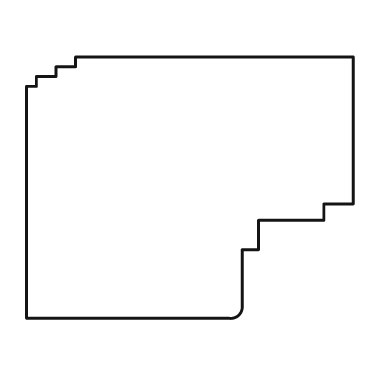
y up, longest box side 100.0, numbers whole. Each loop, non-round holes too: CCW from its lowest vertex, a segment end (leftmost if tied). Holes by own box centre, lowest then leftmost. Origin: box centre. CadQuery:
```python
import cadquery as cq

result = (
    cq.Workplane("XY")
    .moveTo(-50.0, -40.0)
    .lineTo(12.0, -40.0)
    .threePointArc((15.0, -39.0), (16.0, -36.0))
    .lineTo(16.0, -19.0)
    .lineTo(21.0, -19.0)
    .lineTo(21.0, -10.0)
    .lineTo(41.0, -10.0)
    .lineTo(41.0, -5.0)
    .lineTo(50.0, -5.0)
    .lineTo(50.0, 40.0)
    .lineTo(-35.0, 40.0)
    .lineTo(-35.0, 37.0)
    .lineTo(-41.0, 37.0)
    .lineTo(-41.0, 34.0)
    .lineTo(-47.0, 34.0)
    .lineTo(-47.0, 31.0)
    .lineTo(-50.0, 31.0)
    .close()
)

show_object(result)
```